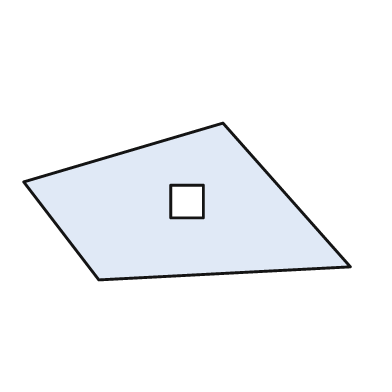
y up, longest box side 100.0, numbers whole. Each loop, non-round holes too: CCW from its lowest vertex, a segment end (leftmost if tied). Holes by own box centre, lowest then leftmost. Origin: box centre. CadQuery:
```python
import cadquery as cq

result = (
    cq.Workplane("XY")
    .moveTo(-27.0, -24.0)
    .lineTo(50.0, -20.0)
    .lineTo(11.0, 24.0)
    .lineTo(-50.0, 6.0)
    .close()
    .moveTo(-5.0, -5.0)
    .lineTo(5.0, -5.0)
    .lineTo(5.0, 5.0)
    .lineTo(-5.0, 5.0)
    .close()
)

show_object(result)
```